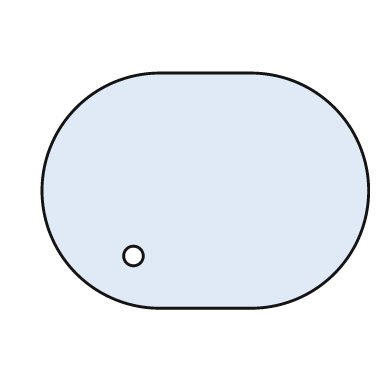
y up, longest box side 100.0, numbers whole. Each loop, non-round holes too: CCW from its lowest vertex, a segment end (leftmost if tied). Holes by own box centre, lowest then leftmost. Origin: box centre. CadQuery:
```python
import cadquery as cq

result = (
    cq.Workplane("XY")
    .moveTo(-14.0, -36.0)
    .lineTo(14.0, -36.0)
    .threePointArc((50.0, 0.0), (14.0, 36.0))
    .lineTo(-14.0, 36.0)
    .threePointArc((-50.0, 0.0), (-14.0, -36.0))
    .close()
    .moveTo(-22.0, -20.0)
    .circle(3.0)
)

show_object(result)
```